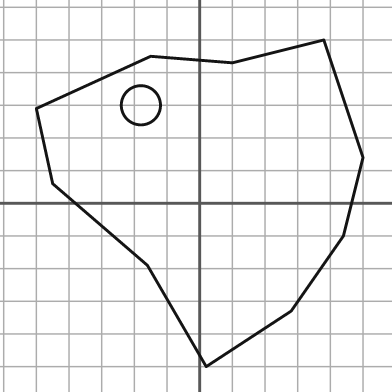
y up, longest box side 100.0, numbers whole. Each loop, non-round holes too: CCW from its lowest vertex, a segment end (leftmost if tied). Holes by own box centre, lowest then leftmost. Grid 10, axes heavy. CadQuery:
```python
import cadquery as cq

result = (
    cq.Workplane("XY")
    .moveTo(2.0, -50.0)
    .lineTo(28.0, -33.0)
    .lineTo(44.0, -10.0)
    .lineTo(50.0, 14.0)
    .lineTo(38.0, 50.0)
    .lineTo(10.0, 43.0)
    .lineTo(-15.0, 45.0)
    .lineTo(-50.0, 29.0)
    .lineTo(-45.0, 6.0)
    .lineTo(-16.0, -19.0)
    .close()
    .moveTo(-18.0, 30.0)
    .circle(6.0)
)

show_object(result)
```